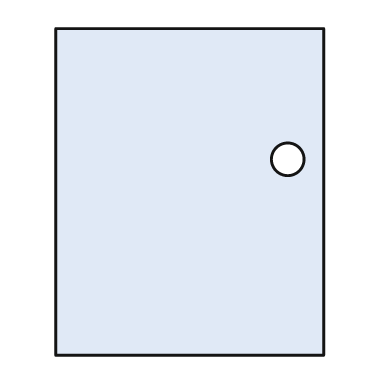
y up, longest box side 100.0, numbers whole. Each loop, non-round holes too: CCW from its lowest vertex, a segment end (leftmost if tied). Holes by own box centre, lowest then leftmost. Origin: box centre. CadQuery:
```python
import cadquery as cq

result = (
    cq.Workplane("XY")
    .moveTo(-41.0, -50.0)
    .lineTo(41.0, -50.0)
    .lineTo(41.0, 50.0)
    .lineTo(-41.0, 50.0)
    .close()
    .moveTo(30.0, 10.0)
    .circle(5.0)
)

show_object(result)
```